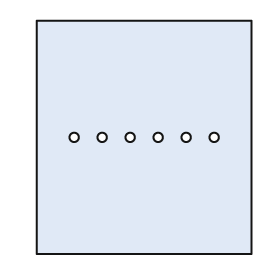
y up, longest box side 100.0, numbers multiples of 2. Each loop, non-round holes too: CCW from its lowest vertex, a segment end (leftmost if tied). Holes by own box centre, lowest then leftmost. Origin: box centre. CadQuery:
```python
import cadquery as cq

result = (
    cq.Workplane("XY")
    .moveTo(-46.0, -50.0)
    .lineTo(46.0, -50.0)
    .lineTo(46.0, 50.0)
    .lineTo(-46.0, 50.0)
    .close()
    .moveTo(-30.0, 0.0)
    .circle(2.0)
    .moveTo(-18.0, 0.0)
    .circle(2.0)
    .moveTo(-6.0, 0.0)
    .circle(2.0)
    .moveTo(6.0, 0.0)
    .circle(2.0)
    .moveTo(18.0, 0.0)
    .circle(2.0)
    .moveTo(30.0, 0.0)
    .circle(2.0)
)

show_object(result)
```